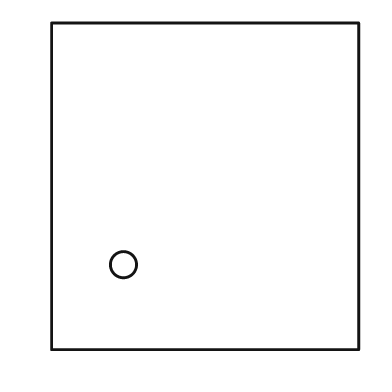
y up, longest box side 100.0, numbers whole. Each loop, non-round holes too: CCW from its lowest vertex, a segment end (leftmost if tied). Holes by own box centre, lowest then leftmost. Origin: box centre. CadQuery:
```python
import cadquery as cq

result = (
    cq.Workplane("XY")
    .moveTo(-47.0, -50.0)
    .lineTo(47.0, -50.0)
    .lineTo(47.0, 50.0)
    .lineTo(-47.0, 50.0)
    .close()
    .moveTo(-25.0, -24.0)
    .circle(4.0)
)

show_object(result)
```